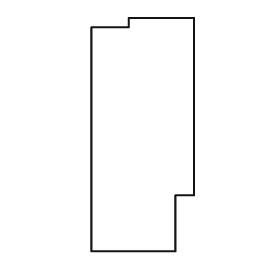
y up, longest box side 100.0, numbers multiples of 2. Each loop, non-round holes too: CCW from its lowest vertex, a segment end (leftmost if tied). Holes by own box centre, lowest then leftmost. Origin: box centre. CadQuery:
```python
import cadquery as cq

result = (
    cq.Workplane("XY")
    .moveTo(-22.0, -50.0)
    .lineTo(14.0, -50.0)
    .lineTo(14.0, -26.0)
    .lineTo(22.0, -26.0)
    .lineTo(22.0, 50.0)
    .lineTo(-6.0, 50.0)
    .lineTo(-6.0, 46.0)
    .lineTo(-22.0, 46.0)
    .close()
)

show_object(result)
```